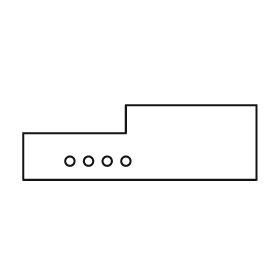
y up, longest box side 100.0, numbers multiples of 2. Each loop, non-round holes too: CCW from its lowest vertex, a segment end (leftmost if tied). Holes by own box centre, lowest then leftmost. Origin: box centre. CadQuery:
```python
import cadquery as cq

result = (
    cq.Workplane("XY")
    .moveTo(-50.0, -16.0)
    .lineTo(50.0, -16.0)
    .lineTo(50.0, 16.0)
    .lineTo(-6.0, 16.0)
    .lineTo(-6.0, 4.0)
    .lineTo(-50.0, 4.0)
    .close()
    .moveTo(-30.0, -8.0)
    .circle(2.0)
    .moveTo(-22.0, -8.0)
    .circle(2.0)
    .moveTo(-14.0, -8.0)
    .circle(2.0)
    .moveTo(-6.0, -8.0)
    .circle(2.0)
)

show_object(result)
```